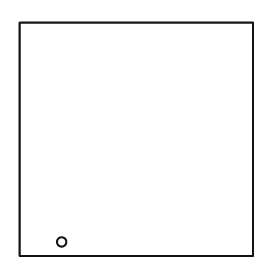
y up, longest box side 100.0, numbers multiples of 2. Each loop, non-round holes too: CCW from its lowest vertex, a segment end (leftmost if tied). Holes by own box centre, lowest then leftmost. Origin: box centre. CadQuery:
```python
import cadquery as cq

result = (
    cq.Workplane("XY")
    .moveTo(-50.0, -50.0)
    .lineTo(50.0, -50.0)
    .lineTo(50.0, 50.0)
    .lineTo(-50.0, 50.0)
    .close()
    .moveTo(-32.0, -44.0)
    .circle(2.0)
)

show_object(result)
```